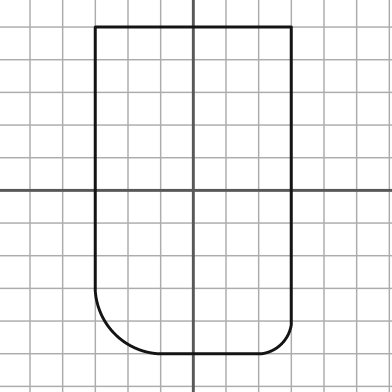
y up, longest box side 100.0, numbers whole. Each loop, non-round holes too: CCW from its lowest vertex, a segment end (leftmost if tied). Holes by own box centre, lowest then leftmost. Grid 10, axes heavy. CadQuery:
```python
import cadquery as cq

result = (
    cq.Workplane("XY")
    .moveTo(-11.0, -50.0)
    .lineTo(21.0, -50.0)
    .threePointArc((27.0, -47.0), (30.0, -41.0))
    .lineTo(30.0, 50.0)
    .lineTo(-30.0, 50.0)
    .lineTo(-30.0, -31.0)
    .threePointArc((-24.0, -44.0), (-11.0, -50.0))
    .close()
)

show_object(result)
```